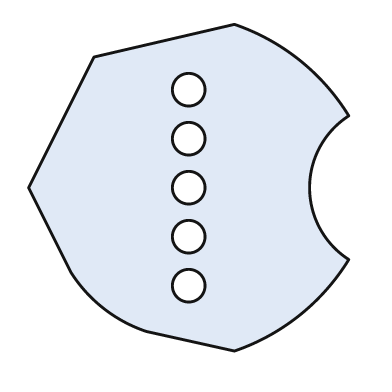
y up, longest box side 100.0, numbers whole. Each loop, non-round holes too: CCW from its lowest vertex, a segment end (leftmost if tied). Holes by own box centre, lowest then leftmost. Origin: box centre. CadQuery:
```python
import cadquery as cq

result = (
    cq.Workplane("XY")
    .moveTo(14.0, -50.0)
    .threePointArc((34.0, -39.0), (49.0, -22.0))
    .threePointArc((37.0, 0.0), (49.0, 22.0))
    .threePointArc((34.0, 39.0), (14.0, 50.0))
    .lineTo(-29.0, 40.0)
    .lineTo(-49.0, 0.0)
    .lineTo(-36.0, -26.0)
    .threePointArc((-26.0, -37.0), (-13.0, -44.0))
    .close()
    .moveTo(0.0, -30.0)
    .circle(5.0)
    .moveTo(0.0, -15.0)
    .circle(5.0)
    .moveTo(0.0, 0.0)
    .circle(5.0)
    .moveTo(0.0, 15.0)
    .circle(5.0)
    .moveTo(0.0, 30.0)
    .circle(5.0)
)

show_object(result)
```